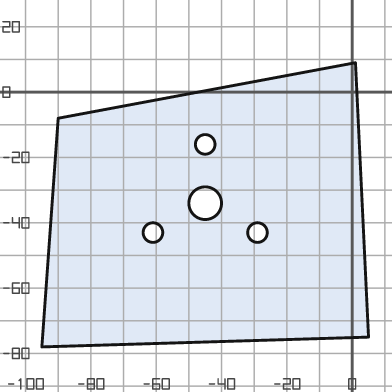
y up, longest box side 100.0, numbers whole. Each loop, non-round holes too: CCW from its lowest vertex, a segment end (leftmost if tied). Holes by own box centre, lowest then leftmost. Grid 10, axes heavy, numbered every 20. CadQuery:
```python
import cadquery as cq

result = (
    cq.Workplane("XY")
    .moveTo(-95.0, -78.0)
    .lineTo(5.0, -75.0)
    .lineTo(1.0, 9.0)
    .lineTo(-90.0, -8.0)
    .close()
    .moveTo(-61.0, -43.0)
    .circle(3.0)
    .moveTo(-29.0, -43.0)
    .circle(3.0)
    .moveTo(-45.0, -34.0)
    .circle(5.0)
    .moveTo(-45.0, -16.0)
    .circle(3.0)
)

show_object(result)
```